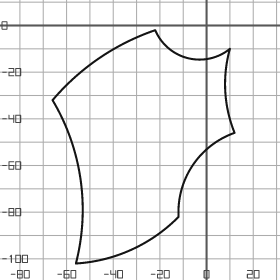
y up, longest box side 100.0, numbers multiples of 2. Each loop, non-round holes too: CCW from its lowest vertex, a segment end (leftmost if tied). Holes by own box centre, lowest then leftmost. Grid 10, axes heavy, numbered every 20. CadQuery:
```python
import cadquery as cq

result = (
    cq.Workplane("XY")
    .moveTo(-56.0, -102.0)
    .threePointArc((-32.0, -96.0), (-12.0, -82.0))
    .threePointArc((-6.0, -60.0), (12.0, -46.0))
    .threePointArc((8.0, -28.0), (10.0, -10.0))
    .threePointArc((-8.0, -14.0), (-22.0, -2.0))
    .threePointArc((-46.0, -14.0), (-66.0, -32.0))
    .threePointArc((-54.0, -66.0), (-56.0, -102.0))
    .close()
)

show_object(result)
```